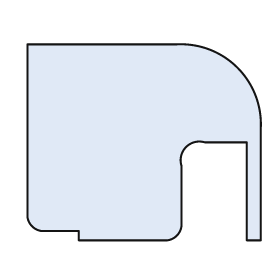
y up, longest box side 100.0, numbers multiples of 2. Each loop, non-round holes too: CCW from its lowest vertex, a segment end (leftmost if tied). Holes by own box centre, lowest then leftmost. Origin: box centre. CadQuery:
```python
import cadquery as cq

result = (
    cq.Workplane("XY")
    .moveTo(-28.0, -42.0)
    .lineTo(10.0, -42.0)
    .threePointArc((14.0, -40.0), (16.0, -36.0))
    .lineTo(16.0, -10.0)
    .threePointArc((18.0, -2.0), (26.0, 0.0))
    .lineTo(44.0, 0.0)
    .lineTo(44.0, -42.0)
    .lineTo(50.0, -42.0)
    .lineTo(50.0, 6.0)
    .threePointArc((40.0, 32.0), (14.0, 42.0))
    .lineTo(-50.0, 42.0)
    .lineTo(-50.0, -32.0)
    .threePointArc((-48.0, -36.0), (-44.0, -38.0))
    .lineTo(-28.0, -38.0)
    .close()
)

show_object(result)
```